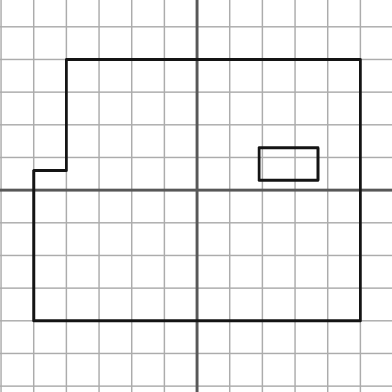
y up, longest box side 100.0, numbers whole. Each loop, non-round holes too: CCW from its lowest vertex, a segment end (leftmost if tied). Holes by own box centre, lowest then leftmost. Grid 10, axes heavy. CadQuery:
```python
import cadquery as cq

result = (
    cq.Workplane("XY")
    .moveTo(-50.0, -40.0)
    .lineTo(50.0, -40.0)
    .lineTo(50.0, 40.0)
    .lineTo(-40.0, 40.0)
    .lineTo(-40.0, 6.0)
    .lineTo(-50.0, 6.0)
    .close()
    .moveTo(19.0, 3.0)
    .lineTo(37.0, 3.0)
    .lineTo(37.0, 13.0)
    .lineTo(19.0, 13.0)
    .close()
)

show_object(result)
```